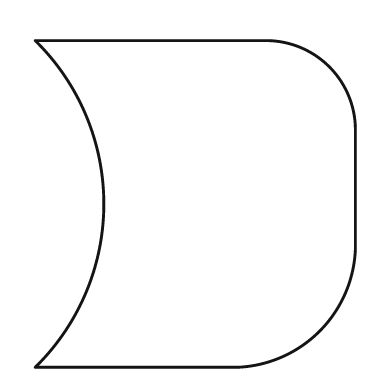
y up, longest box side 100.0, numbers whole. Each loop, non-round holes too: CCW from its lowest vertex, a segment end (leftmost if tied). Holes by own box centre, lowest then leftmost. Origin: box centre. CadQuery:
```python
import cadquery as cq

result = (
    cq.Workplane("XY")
    .moveTo(-49.0, -50.0)
    .lineTo(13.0, -50.0)
    .threePointArc((38.0, -39.0), (49.0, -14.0))
    .lineTo(49.0, 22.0)
    .threePointArc((41.0, 42.0), (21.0, 50.0))
    .lineTo(-49.0, 50.0)
    .threePointArc((-28.0, 0.0), (-49.0, -50.0))
    .close()
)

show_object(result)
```